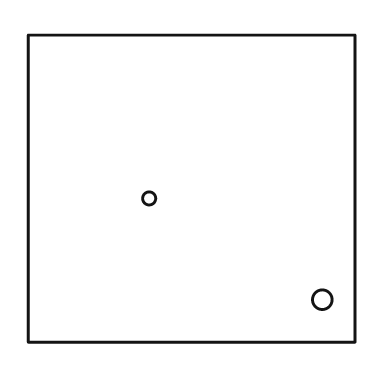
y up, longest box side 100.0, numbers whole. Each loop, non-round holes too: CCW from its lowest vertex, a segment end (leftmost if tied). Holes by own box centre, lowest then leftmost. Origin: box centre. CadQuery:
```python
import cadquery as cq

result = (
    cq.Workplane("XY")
    .moveTo(-50.0, -47.0)
    .lineTo(50.0, -47.0)
    .lineTo(50.0, 47.0)
    .lineTo(-50.0, 47.0)
    .close()
    .moveTo(40.0, -34.0)
    .circle(3.0)
    .moveTo(-13.0, -3.0)
    .circle(2.0)
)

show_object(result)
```